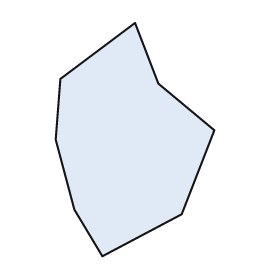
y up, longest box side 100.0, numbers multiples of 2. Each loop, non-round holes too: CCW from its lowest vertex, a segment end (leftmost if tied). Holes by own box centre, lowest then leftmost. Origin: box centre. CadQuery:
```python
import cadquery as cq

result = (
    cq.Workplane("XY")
    .moveTo(-14.0, -50.0)
    .lineTo(20.0, -32.0)
    .lineTo(34.0, 4.0)
    .lineTo(10.0, 24.0)
    .lineTo(0.0, 50.0)
    .lineTo(-32.0, 26.0)
    .lineTo(-34.0, 0.0)
    .lineTo(-26.0, -30.0)
    .close()
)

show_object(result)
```